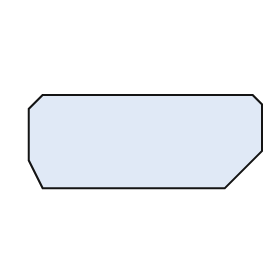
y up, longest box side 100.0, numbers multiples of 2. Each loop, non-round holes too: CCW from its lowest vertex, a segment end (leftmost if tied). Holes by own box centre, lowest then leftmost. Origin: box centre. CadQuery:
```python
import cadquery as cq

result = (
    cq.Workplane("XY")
    .moveTo(-44.0, -20.0)
    .lineTo(34.0, -20.0)
    .lineTo(50.0, -4.0)
    .lineTo(50.0, 16.0)
    .lineTo(46.0, 20.0)
    .lineTo(-44.0, 20.0)
    .lineTo(-50.0, 14.0)
    .lineTo(-50.0, -8.0)
    .close()
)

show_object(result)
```